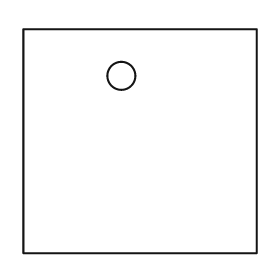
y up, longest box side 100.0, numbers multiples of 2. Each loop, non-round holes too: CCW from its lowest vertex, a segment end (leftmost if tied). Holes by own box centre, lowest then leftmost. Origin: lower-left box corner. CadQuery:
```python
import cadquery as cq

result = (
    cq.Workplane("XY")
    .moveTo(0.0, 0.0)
    .lineTo(100.0, 0.0)
    .lineTo(100.0, 96.0)
    .lineTo(0.0, 96.0)
    .close()
    .moveTo(42.0, 76.0)
    .circle(6.0)
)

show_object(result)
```